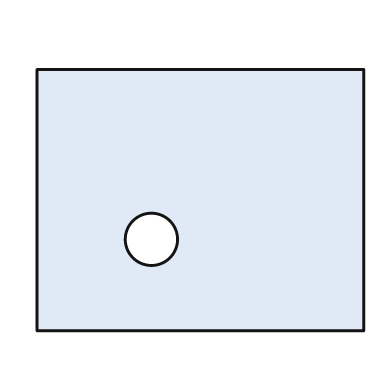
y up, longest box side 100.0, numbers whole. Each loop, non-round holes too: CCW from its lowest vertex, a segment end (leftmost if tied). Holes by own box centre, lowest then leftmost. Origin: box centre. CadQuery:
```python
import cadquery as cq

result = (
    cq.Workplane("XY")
    .moveTo(-50.0, -40.0)
    .lineTo(50.0, -40.0)
    .lineTo(50.0, 40.0)
    .lineTo(-50.0, 40.0)
    .close()
    .moveTo(-15.0, -12.0)
    .circle(8.0)
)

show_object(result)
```